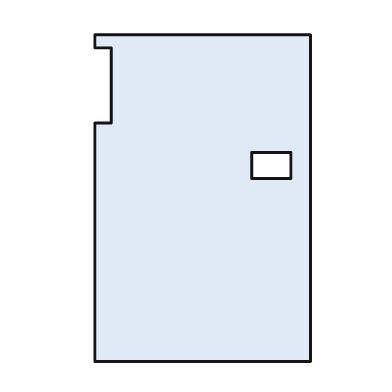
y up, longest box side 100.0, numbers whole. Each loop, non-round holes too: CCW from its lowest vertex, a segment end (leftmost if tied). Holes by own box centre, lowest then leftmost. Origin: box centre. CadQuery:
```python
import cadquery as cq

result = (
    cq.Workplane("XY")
    .moveTo(-33.0, -50.0)
    .lineTo(33.0, -50.0)
    .lineTo(33.0, 50.0)
    .lineTo(-33.0, 50.0)
    .lineTo(-33.0, 46.0)
    .lineTo(-28.0, 46.0)
    .lineTo(-28.0, 23.0)
    .lineTo(-33.0, 23.0)
    .close()
    .moveTo(15.0, 6.0)
    .lineTo(27.0, 6.0)
    .lineTo(27.0, 14.0)
    .lineTo(15.0, 14.0)
    .close()
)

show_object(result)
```